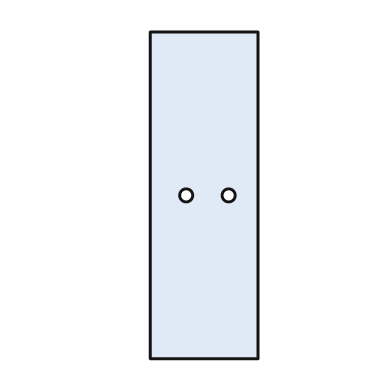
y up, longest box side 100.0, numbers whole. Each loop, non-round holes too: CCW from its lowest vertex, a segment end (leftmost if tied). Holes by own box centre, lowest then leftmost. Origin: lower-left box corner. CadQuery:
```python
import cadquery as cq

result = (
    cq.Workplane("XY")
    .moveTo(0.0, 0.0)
    .lineTo(33.0, 0.0)
    .lineTo(33.0, 100.0)
    .lineTo(0.0, 100.0)
    .close()
    .moveTo(11.0, 50.0)
    .circle(2.0)
    .moveTo(24.0, 50.0)
    .circle(2.0)
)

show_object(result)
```